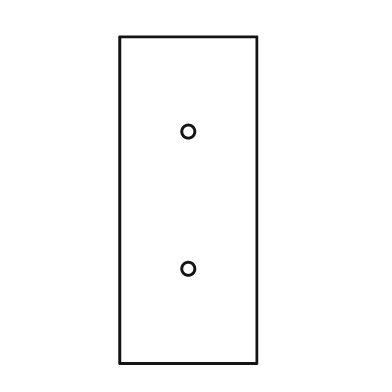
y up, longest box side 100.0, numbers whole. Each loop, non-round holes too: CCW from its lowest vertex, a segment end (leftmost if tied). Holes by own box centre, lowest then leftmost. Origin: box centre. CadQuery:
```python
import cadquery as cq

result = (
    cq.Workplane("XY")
    .moveTo(-21.0, -50.0)
    .lineTo(21.0, -50.0)
    .lineTo(21.0, 50.0)
    .lineTo(-21.0, 50.0)
    .close()
    .moveTo(0.0, -21.0)
    .circle(2.0)
    .moveTo(0.0, 21.0)
    .circle(2.0)
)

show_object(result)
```